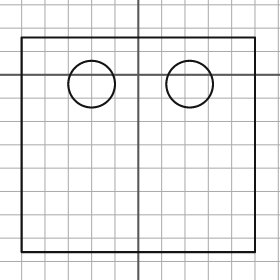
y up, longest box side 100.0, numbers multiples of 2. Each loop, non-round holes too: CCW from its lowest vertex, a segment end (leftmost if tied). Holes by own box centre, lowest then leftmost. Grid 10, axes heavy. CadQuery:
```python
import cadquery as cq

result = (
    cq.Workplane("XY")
    .moveTo(-50.0, -76.0)
    .lineTo(50.0, -76.0)
    .lineTo(50.0, 16.0)
    .lineTo(-50.0, 16.0)
    .close()
    .moveTo(-20.0, -4.0)
    .circle(10.0)
    .moveTo(22.0, -4.0)
    .circle(10.0)
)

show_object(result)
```